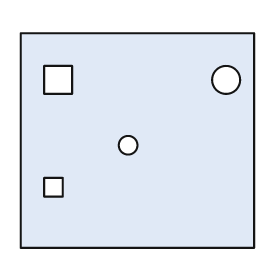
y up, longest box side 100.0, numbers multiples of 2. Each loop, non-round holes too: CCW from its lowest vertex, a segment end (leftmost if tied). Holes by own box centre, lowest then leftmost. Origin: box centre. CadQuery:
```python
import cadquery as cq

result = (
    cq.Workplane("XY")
    .moveTo(-50.0, -46.0)
    .lineTo(50.0, -46.0)
    .lineTo(50.0, 46.0)
    .lineTo(-50.0, 46.0)
    .close()
    .moveTo(-40.0, -24.0)
    .lineTo(-32.0, -24.0)
    .lineTo(-32.0, -16.0)
    .lineTo(-40.0, -16.0)
    .close()
    .moveTo(-4.0, -2.0)
    .circle(4.0)
    .moveTo(-40.0, 20.0)
    .lineTo(-28.0, 20.0)
    .lineTo(-28.0, 32.0)
    .lineTo(-40.0, 32.0)
    .close()
    .moveTo(38.0, 26.0)
    .circle(6.0)
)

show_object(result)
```